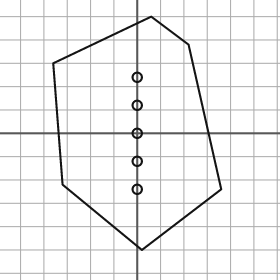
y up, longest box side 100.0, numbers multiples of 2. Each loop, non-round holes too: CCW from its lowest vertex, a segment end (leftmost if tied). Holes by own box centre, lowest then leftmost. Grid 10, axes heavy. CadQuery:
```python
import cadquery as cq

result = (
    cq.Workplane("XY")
    .moveTo(2.0, -50.0)
    .lineTo(36.0, -24.0)
    .lineTo(22.0, 38.0)
    .lineTo(6.0, 50.0)
    .lineTo(-36.0, 30.0)
    .lineTo(-32.0, -22.0)
    .close()
    .moveTo(0.0, -24.0)
    .circle(2.0)
    .moveTo(0.0, -12.0)
    .circle(2.0)
    .moveTo(0.0, 0.0)
    .circle(2.0)
    .moveTo(0.0, 12.0)
    .circle(2.0)
    .moveTo(0.0, 24.0)
    .circle(2.0)
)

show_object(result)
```